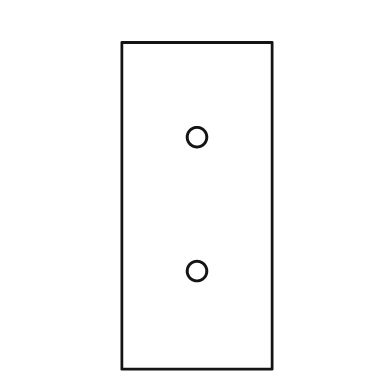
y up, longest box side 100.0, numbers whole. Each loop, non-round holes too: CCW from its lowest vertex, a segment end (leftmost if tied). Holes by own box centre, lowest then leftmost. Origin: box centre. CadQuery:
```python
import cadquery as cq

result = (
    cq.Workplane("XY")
    .moveTo(-23.0, -50.0)
    .lineTo(23.0, -50.0)
    .lineTo(23.0, 50.0)
    .lineTo(-23.0, 50.0)
    .close()
    .moveTo(0.0, -20.0)
    .circle(3.0)
    .moveTo(0.0, 21.0)
    .circle(3.0)
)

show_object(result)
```